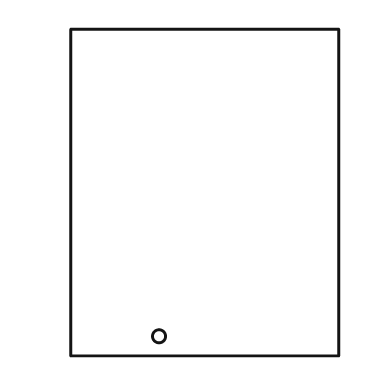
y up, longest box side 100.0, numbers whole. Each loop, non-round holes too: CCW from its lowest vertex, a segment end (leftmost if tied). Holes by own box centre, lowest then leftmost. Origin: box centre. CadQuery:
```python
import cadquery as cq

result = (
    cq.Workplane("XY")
    .moveTo(-41.0, -50.0)
    .lineTo(41.0, -50.0)
    .lineTo(41.0, 50.0)
    .lineTo(-41.0, 50.0)
    .close()
    .moveTo(-14.0, -44.0)
    .circle(2.0)
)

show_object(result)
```